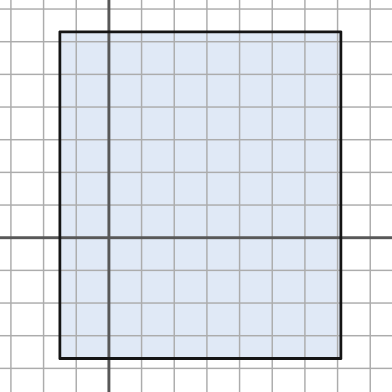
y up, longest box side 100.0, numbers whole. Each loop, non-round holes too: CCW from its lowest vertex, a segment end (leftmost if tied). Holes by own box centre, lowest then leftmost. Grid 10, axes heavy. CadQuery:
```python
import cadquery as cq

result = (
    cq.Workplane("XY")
    .moveTo(-15.0, -37.0)
    .lineTo(71.0, -37.0)
    .lineTo(71.0, 63.0)
    .lineTo(-15.0, 63.0)
    .close()
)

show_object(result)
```